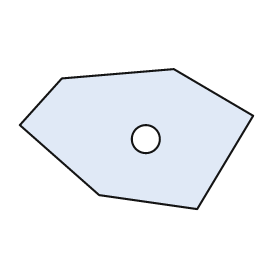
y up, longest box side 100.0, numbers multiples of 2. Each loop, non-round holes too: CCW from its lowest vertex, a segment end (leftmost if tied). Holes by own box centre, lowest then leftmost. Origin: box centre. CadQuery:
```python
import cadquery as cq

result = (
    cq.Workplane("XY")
    .moveTo(26.0, -30.0)
    .lineTo(50.0, 10.0)
    .lineTo(16.0, 30.0)
    .lineTo(-32.0, 26.0)
    .lineTo(-50.0, 6.0)
    .lineTo(-16.0, -24.0)
    .close()
    .moveTo(4.0, 0.0)
    .circle(6.0)
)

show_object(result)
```